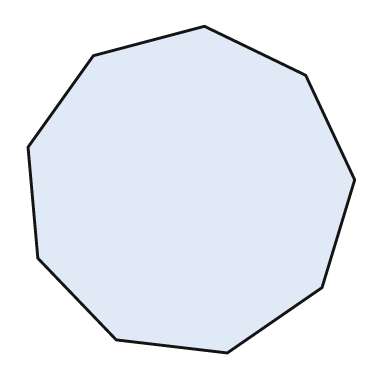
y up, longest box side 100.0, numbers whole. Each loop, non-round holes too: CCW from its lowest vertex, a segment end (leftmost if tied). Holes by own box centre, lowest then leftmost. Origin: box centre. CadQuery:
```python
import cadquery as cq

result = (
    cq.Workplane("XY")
    .moveTo(11.0, -50.0)
    .lineTo(40.0, -30.0)
    .lineTo(50.0, 3.0)
    .lineTo(35.0, 35.0)
    .lineTo(4.0, 50.0)
    .lineTo(-30.0, 41.0)
    .lineTo(-50.0, 13.0)
    .lineTo(-47.0, -21.0)
    .lineTo(-23.0, -46.0)
    .close()
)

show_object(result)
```